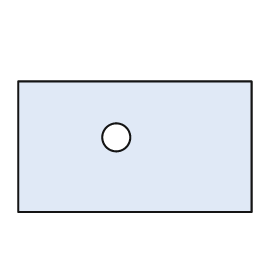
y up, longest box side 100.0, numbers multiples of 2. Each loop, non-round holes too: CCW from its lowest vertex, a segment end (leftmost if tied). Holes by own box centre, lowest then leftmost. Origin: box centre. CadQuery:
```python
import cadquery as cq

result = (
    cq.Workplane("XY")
    .moveTo(-50.0, -28.0)
    .lineTo(50.0, -28.0)
    .lineTo(50.0, 28.0)
    .lineTo(-50.0, 28.0)
    .close()
    .moveTo(-8.0, 4.0)
    .circle(6.0)
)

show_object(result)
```